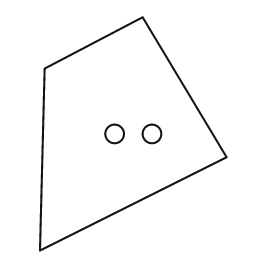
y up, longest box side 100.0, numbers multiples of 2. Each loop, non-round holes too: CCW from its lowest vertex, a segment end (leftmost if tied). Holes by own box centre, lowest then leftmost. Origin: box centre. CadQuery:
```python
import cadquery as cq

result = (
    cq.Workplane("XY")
    .moveTo(-40.0, -50.0)
    .lineTo(40.0, -10.0)
    .lineTo(4.0, 50.0)
    .lineTo(-38.0, 28.0)
    .close()
    .moveTo(-8.0, 0.0)
    .circle(4.0)
    .moveTo(8.0, 0.0)
    .circle(4.0)
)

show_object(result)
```